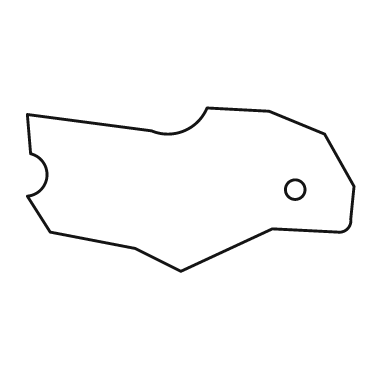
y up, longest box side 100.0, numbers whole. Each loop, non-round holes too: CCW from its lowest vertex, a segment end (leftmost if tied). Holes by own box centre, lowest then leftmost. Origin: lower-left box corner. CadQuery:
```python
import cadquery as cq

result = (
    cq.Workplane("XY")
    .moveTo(47.0, 0.0)
    .lineTo(75.0, 13.0)
    .lineTo(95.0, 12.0)
    .threePointArc((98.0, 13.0), (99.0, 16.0))
    .lineTo(100.0, 26.0)
    .lineTo(91.0, 42.0)
    .lineTo(74.0, 49.0)
    .lineTo(55.0, 50.0)
    .threePointArc((48.0, 43.0), (38.0, 43.0))
    .lineTo(0.0, 48.0)
    .lineTo(1.0, 36.0)
    .threePointArc((6.0, 29.0), (0.0, 23.0))
    .lineTo(7.0, 12.0)
    .lineTo(33.0, 7.0)
    .close()
    .moveTo(82.0, 25.0)
    .circle(3.0)
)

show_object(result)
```